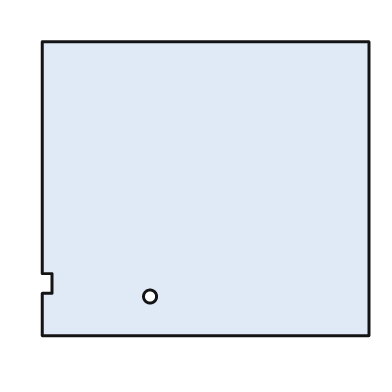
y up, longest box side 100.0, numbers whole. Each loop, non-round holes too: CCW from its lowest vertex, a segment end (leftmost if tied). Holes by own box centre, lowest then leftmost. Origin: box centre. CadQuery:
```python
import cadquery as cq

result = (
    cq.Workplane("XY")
    .moveTo(-50.0, -45.0)
    .lineTo(50.0, -45.0)
    .lineTo(50.0, 45.0)
    .lineTo(-50.0, 45.0)
    .lineTo(-50.0, -26.0)
    .lineTo(-47.0, -26.0)
    .lineTo(-47.0, -32.0)
    .lineTo(-50.0, -32.0)
    .close()
    .moveTo(-17.0, -33.0)
    .circle(2.0)
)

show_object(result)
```